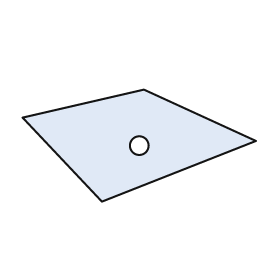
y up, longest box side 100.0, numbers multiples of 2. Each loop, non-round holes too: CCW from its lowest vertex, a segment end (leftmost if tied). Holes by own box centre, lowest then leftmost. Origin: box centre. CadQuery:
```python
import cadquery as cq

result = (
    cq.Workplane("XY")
    .moveTo(-16.0, -24.0)
    .lineTo(50.0, 2.0)
    .lineTo(2.0, 24.0)
    .lineTo(-50.0, 12.0)
    .close()
    .moveTo(0.0, 0.0)
    .circle(4.0)
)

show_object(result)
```